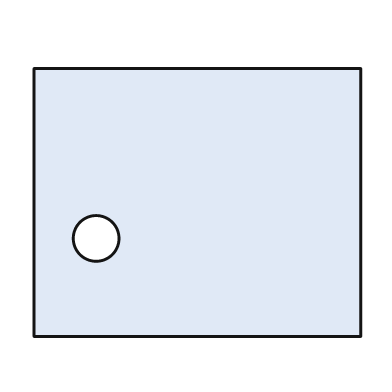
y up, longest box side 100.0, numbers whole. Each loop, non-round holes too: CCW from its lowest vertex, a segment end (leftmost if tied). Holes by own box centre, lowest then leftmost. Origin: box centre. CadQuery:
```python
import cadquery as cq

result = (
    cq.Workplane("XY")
    .moveTo(-50.0, -41.0)
    .lineTo(50.0, -41.0)
    .lineTo(50.0, 41.0)
    .lineTo(-50.0, 41.0)
    .close()
    .moveTo(-31.0, -11.0)
    .circle(7.0)
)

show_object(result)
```